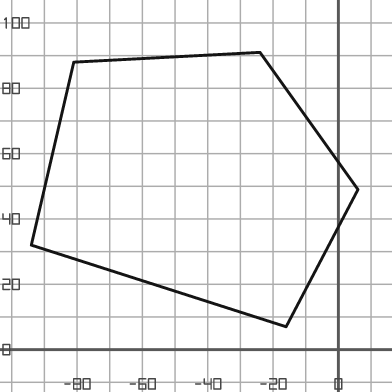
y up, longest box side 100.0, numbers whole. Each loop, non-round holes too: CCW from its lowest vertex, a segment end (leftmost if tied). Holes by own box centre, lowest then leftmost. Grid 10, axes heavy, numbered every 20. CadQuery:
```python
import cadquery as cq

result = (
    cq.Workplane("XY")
    .moveTo(-16.0, 7.0)
    .lineTo(6.0, 49.0)
    .lineTo(-24.0, 91.0)
    .lineTo(-81.0, 88.0)
    .lineTo(-94.0, 32.0)
    .close()
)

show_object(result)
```